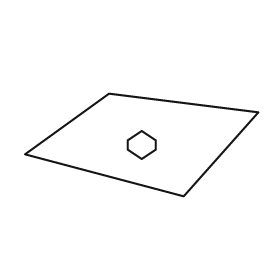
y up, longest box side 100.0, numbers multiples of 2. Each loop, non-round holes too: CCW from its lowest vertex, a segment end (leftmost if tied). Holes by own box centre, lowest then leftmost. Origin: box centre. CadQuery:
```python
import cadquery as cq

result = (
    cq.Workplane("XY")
    .moveTo(18.0, -22.0)
    .lineTo(50.0, 14.0)
    .lineTo(-14.0, 22.0)
    .lineTo(-50.0, -4.0)
    .close()
    .moveTo(0.0, -6.0)
    .lineTo(6.0, -2.0)
    .lineTo(6.0, 2.0)
    .lineTo(0.0, 6.0)
    .lineTo(-6.0, 2.0)
    .lineTo(-6.0, -2.0)
    .close()
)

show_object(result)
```